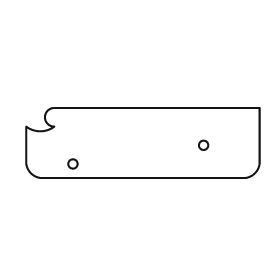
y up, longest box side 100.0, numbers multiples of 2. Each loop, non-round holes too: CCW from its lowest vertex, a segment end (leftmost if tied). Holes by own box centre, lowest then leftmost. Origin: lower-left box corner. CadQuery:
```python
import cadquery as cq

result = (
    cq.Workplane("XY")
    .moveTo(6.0, 0.0)
    .lineTo(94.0, 0.0)
    .threePointArc((98.0, 2.0), (100.0, 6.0))
    .lineTo(100.0, 30.0)
    .lineTo(12.0, 30.0)
    .threePointArc((8.0, 26.0), (12.0, 22.0))
    .threePointArc((6.0, 20.0), (0.0, 22.0))
    .lineTo(0.0, 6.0)
    .threePointArc((2.0, 2.0), (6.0, 0.0))
    .close()
    .moveTo(20.0, 6.0)
    .circle(2.0)
    .moveTo(76.0, 14.0)
    .circle(2.0)
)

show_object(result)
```